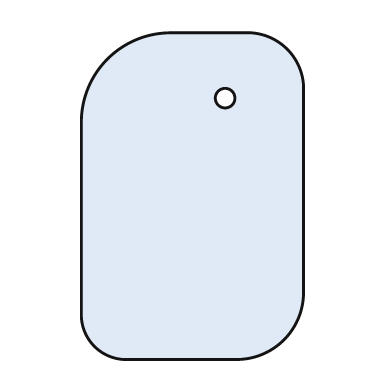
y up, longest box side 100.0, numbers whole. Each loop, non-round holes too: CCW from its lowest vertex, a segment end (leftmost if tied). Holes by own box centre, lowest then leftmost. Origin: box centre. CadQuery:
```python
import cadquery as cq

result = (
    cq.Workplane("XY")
    .moveTo(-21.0, -50.0)
    .lineTo(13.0, -50.0)
    .threePointArc((28.0, -44.0), (34.0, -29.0))
    .lineTo(34.0, 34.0)
    .threePointArc((29.0, 45.0), (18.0, 50.0))
    .lineTo(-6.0, 50.0)
    .threePointArc((-26.0, 42.0), (-34.0, 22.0))
    .lineTo(-34.0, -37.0)
    .threePointArc((-30.0, -46.0), (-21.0, -50.0))
    .close()
    .moveTo(10.0, 30.0)
    .circle(3.0)
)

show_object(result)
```